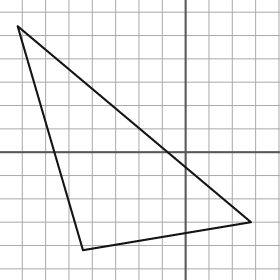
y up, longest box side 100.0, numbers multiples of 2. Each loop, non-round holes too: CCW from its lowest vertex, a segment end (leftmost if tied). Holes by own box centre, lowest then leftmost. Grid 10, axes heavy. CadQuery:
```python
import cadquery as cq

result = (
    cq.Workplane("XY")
    .moveTo(-44.0, -42.0)
    .lineTo(28.0, -30.0)
    .lineTo(-72.0, 54.0)
    .close()
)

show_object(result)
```